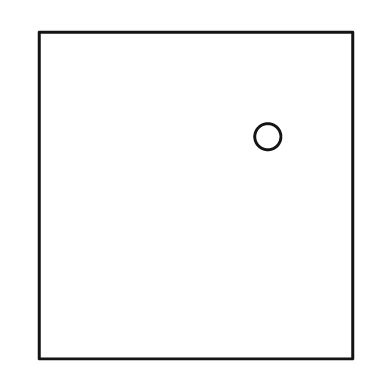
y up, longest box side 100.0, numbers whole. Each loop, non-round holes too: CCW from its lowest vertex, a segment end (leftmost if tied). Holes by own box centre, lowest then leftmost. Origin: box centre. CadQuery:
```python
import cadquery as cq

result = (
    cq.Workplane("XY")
    .moveTo(-48.0, -50.0)
    .lineTo(48.0, -50.0)
    .lineTo(48.0, 50.0)
    .lineTo(-48.0, 50.0)
    .close()
    .moveTo(22.0, 18.0)
    .circle(4.0)
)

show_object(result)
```